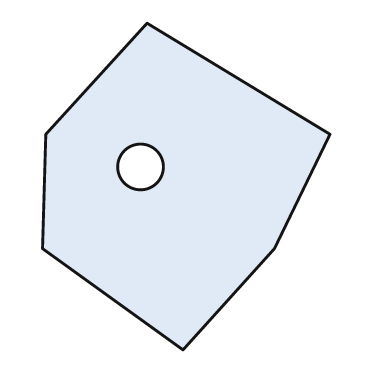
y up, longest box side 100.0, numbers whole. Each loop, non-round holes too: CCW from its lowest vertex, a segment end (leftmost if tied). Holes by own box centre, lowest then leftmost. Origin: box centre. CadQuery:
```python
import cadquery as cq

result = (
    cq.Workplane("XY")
    .moveTo(-1.0, -50.0)
    .lineTo(27.0, -19.0)
    .lineTo(44.0, 16.0)
    .lineTo(-12.0, 50.0)
    .lineTo(-43.0, 16.0)
    .lineTo(-44.0, -19.0)
    .close()
    .moveTo(-14.0, 6.0)
    .circle(7.0)
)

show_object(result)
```